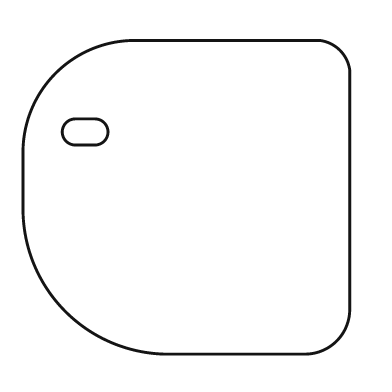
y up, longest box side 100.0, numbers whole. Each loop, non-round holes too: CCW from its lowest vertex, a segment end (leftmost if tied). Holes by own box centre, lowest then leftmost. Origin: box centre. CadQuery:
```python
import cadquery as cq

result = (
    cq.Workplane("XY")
    .moveTo(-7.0, -48.0)
    .lineTo(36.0, -48.0)
    .threePointArc((46.0, -44.0), (50.0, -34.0))
    .lineTo(50.0, 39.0)
    .threePointArc((47.0, 45.0), (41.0, 48.0))
    .lineTo(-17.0, 48.0)
    .threePointArc((-40.0, 38.0), (-50.0, 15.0))
    .lineTo(-50.0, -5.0)
    .threePointArc((-37.0, -35.0), (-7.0, -48.0))
    .close()
    .moveTo(-34.0, 16.0)
    .lineTo(-28.0, 16.0)
    .threePointArc((-24.0, 20.0), (-28.0, 24.0))
    .lineTo(-34.0, 24.0)
    .threePointArc((-38.0, 20.0), (-34.0, 16.0))
    .close()
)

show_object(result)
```